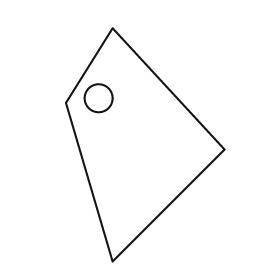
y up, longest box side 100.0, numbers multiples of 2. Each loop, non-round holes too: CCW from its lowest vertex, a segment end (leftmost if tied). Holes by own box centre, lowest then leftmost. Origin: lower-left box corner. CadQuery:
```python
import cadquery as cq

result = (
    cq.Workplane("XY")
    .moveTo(20.0, 0.0)
    .lineTo(68.0, 48.0)
    .lineTo(20.0, 100.0)
    .lineTo(0.0, 68.0)
    .close()
    .moveTo(14.0, 70.0)
    .circle(6.0)
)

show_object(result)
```